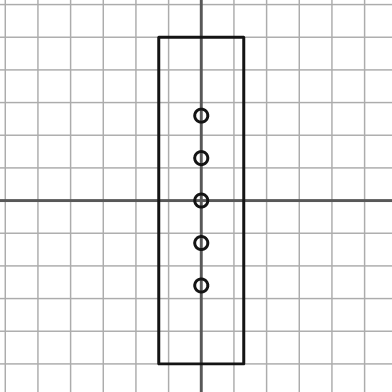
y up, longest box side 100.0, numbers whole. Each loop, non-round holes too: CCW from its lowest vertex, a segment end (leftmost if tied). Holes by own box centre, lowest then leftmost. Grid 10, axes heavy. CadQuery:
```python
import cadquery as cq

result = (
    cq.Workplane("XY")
    .moveTo(-13.0, -50.0)
    .lineTo(13.0, -50.0)
    .lineTo(13.0, 50.0)
    .lineTo(-13.0, 50.0)
    .close()
    .moveTo(0.0, -26.0)
    .circle(2.0)
    .moveTo(0.0, -13.0)
    .circle(2.0)
    .moveTo(0.0, 0.0)
    .circle(2.0)
    .moveTo(0.0, 13.0)
    .circle(2.0)
    .moveTo(0.0, 26.0)
    .circle(2.0)
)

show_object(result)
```